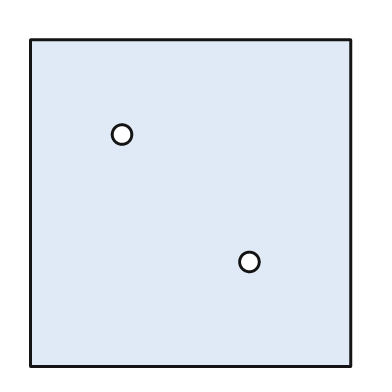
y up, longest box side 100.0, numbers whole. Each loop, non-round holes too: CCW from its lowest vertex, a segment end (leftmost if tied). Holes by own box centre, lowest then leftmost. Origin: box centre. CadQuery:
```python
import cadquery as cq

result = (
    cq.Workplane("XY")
    .moveTo(-49.0, -50.0)
    .lineTo(49.0, -50.0)
    .lineTo(49.0, 50.0)
    .lineTo(-49.0, 50.0)
    .close()
    .moveTo(18.0, -18.0)
    .circle(3.0)
    .moveTo(-21.0, 21.0)
    .circle(3.0)
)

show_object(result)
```